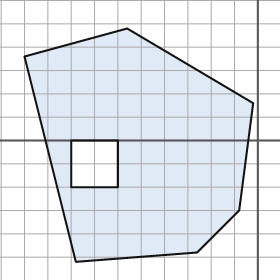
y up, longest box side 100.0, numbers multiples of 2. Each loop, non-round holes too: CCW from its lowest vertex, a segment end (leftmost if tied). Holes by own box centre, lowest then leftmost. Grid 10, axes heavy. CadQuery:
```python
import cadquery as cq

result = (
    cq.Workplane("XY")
    .moveTo(-78.0, -52.0)
    .lineTo(-26.0, -48.0)
    .lineTo(-8.0, -30.0)
    .lineTo(-2.0, 16.0)
    .lineTo(-56.0, 48.0)
    .lineTo(-100.0, 36.0)
    .close()
    .moveTo(-80.0, -20.0)
    .lineTo(-60.0, -20.0)
    .lineTo(-60.0, 0.0)
    .lineTo(-80.0, 0.0)
    .close()
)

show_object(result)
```